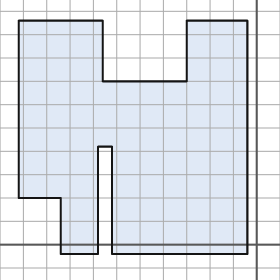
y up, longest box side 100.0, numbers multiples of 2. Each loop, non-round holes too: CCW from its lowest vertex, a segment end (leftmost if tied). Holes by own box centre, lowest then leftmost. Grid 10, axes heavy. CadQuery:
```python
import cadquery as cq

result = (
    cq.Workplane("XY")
    .moveTo(-84.0, -4.0)
    .lineTo(-68.0, -4.0)
    .lineTo(-68.0, 42.0)
    .lineTo(-62.0, 42.0)
    .lineTo(-62.0, -4.0)
    .lineTo(-4.0, -4.0)
    .lineTo(-4.0, 96.0)
    .lineTo(-30.0, 96.0)
    .lineTo(-30.0, 70.0)
    .lineTo(-66.0, 70.0)
    .lineTo(-66.0, 96.0)
    .lineTo(-102.0, 96.0)
    .lineTo(-102.0, 20.0)
    .lineTo(-84.0, 20.0)
    .close()
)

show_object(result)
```